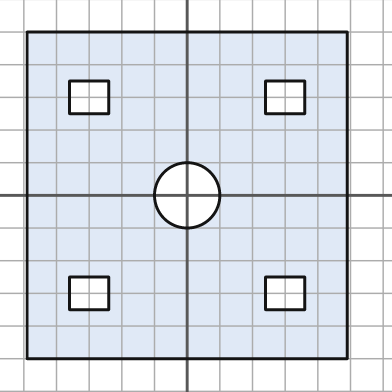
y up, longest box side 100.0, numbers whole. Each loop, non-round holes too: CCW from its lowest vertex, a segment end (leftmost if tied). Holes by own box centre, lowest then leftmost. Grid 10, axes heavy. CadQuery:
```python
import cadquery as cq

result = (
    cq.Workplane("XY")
    .moveTo(-49.0, -50.0)
    .lineTo(49.0, -50.0)
    .lineTo(49.0, 50.0)
    .lineTo(-49.0, 50.0)
    .close()
    .moveTo(-36.0, -35.0)
    .lineTo(-24.0, -35.0)
    .lineTo(-24.0, -25.0)
    .lineTo(-36.0, -25.0)
    .close()
    .moveTo(24.0, -35.0)
    .lineTo(36.0, -35.0)
    .lineTo(36.0, -25.0)
    .lineTo(24.0, -25.0)
    .close()
    .moveTo(0.0, 0.0)
    .circle(10.0)
    .moveTo(-36.0, 25.0)
    .lineTo(-24.0, 25.0)
    .lineTo(-24.0, 35.0)
    .lineTo(-36.0, 35.0)
    .close()
    .moveTo(24.0, 25.0)
    .lineTo(36.0, 25.0)
    .lineTo(36.0, 35.0)
    .lineTo(24.0, 35.0)
    .close()
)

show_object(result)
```